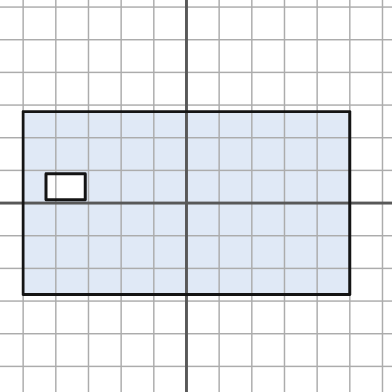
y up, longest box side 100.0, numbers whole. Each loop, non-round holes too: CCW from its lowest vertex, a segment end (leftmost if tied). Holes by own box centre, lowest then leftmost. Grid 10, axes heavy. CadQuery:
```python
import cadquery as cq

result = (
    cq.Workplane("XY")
    .moveTo(-50.0, -28.0)
    .lineTo(50.0, -28.0)
    .lineTo(50.0, 28.0)
    .lineTo(-50.0, 28.0)
    .close()
    .moveTo(-43.0, 1.0)
    .lineTo(-31.0, 1.0)
    .lineTo(-31.0, 9.0)
    .lineTo(-43.0, 9.0)
    .close()
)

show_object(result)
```